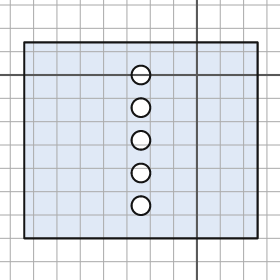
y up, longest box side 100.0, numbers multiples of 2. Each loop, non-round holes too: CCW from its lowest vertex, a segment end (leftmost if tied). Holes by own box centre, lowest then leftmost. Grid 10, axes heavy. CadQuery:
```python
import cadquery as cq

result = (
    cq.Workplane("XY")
    .moveTo(-74.0, -70.0)
    .lineTo(26.0, -70.0)
    .lineTo(26.0, 14.0)
    .lineTo(-74.0, 14.0)
    .close()
    .moveTo(-24.0, -56.0)
    .circle(4.0)
    .moveTo(-24.0, -42.0)
    .circle(4.0)
    .moveTo(-24.0, -28.0)
    .circle(4.0)
    .moveTo(-24.0, -14.0)
    .circle(4.0)
    .moveTo(-24.0, 0.0)
    .circle(4.0)
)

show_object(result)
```